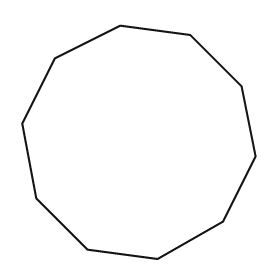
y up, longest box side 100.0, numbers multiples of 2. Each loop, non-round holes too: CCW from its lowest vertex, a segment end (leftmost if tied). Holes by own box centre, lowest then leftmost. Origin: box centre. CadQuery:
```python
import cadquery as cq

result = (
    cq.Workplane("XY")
    .moveTo(8.0, -50.0)
    .lineTo(36.0, -34.0)
    .lineTo(50.0, -6.0)
    .lineTo(44.0, 24.0)
    .lineTo(22.0, 46.0)
    .lineTo(-8.0, 50.0)
    .lineTo(-36.0, 36.0)
    .lineTo(-50.0, 8.0)
    .lineTo(-44.0, -24.0)
    .lineTo(-22.0, -46.0)
    .close()
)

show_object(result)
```